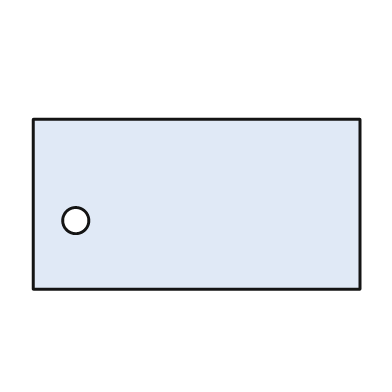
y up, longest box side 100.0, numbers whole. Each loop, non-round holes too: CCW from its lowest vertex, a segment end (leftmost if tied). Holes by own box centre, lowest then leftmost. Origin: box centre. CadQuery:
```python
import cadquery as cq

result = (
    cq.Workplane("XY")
    .moveTo(-50.0, -26.0)
    .lineTo(50.0, -26.0)
    .lineTo(50.0, 26.0)
    .lineTo(-50.0, 26.0)
    .close()
    .moveTo(-37.0, -5.0)
    .circle(4.0)
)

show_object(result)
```